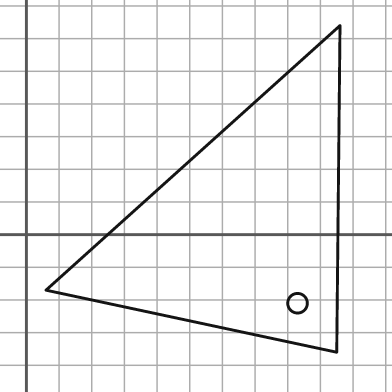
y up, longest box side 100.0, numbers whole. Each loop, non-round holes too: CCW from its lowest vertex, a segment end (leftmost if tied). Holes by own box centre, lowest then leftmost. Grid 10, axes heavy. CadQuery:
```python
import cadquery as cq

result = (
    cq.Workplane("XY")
    .moveTo(95.0, -36.0)
    .lineTo(96.0, 64.0)
    .lineTo(6.0, -17.0)
    .close()
    .moveTo(83.0, -21.0)
    .circle(3.0)
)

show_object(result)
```